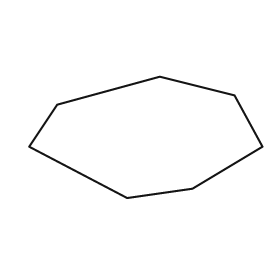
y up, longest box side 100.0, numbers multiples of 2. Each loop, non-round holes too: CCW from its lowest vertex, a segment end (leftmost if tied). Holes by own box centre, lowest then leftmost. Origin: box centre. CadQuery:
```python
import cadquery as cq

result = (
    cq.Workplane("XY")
    .moveTo(-8.0, -26.0)
    .lineTo(20.0, -22.0)
    .lineTo(50.0, -4.0)
    .lineTo(38.0, 18.0)
    .lineTo(6.0, 26.0)
    .lineTo(-38.0, 14.0)
    .lineTo(-50.0, -4.0)
    .close()
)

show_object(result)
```